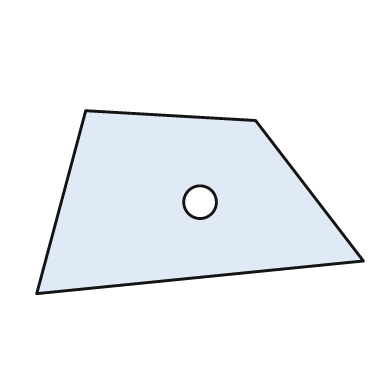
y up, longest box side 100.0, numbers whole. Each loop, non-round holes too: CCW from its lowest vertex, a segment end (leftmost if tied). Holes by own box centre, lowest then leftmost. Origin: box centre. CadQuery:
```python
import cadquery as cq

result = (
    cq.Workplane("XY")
    .moveTo(-50.0, -28.0)
    .lineTo(50.0, -18.0)
    .lineTo(17.0, 25.0)
    .lineTo(-35.0, 28.0)
    .close()
    .moveTo(0.0, 0.0)
    .circle(5.0)
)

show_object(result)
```